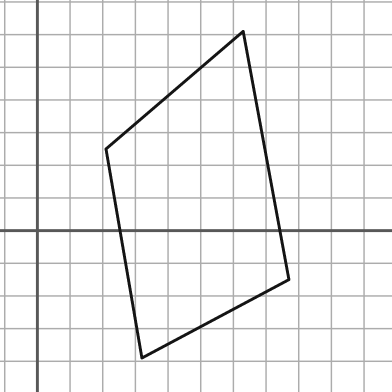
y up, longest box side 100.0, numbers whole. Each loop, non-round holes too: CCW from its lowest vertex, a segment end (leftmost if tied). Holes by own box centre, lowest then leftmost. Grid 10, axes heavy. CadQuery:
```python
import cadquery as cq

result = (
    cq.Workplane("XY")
    .moveTo(32.0, -39.0)
    .lineTo(77.0, -15.0)
    .lineTo(63.0, 61.0)
    .lineTo(21.0, 25.0)
    .close()
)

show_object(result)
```